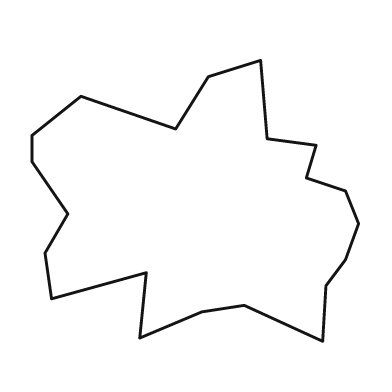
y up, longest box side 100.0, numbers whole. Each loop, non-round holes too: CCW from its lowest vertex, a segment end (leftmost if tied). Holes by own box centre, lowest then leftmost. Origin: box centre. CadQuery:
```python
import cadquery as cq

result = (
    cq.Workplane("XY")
    .moveTo(39.0, -43.0)
    .lineTo(40.0, -26.0)
    .lineTo(46.0, -18.0)
    .lineTo(50.0, -7.0)
    .lineTo(46.0, 3.0)
    .lineTo(34.0, 7.0)
    .lineTo(37.0, 17.0)
    .lineTo(22.0, 19.0)
    .lineTo(20.0, 43.0)
    .lineTo(4.0, 38.0)
    .lineTo(-6.0, 22.0)
    .lineTo(-35.0, 32.0)
    .lineTo(-50.0, 20.0)
    .lineTo(-50.0, 12.0)
    .lineTo(-39.0, -4.0)
    .lineTo(-46.0, -16.0)
    .lineTo(-44.0, -30.0)
    .lineTo(-15.0, -22.0)
    .lineTo(-17.0, -42.0)
    .lineTo(2.0, -34.0)
    .lineTo(15.0, -32.0)
    .close()
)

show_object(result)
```